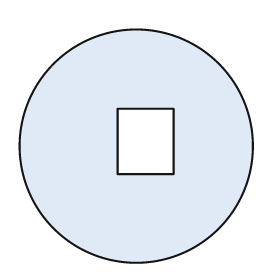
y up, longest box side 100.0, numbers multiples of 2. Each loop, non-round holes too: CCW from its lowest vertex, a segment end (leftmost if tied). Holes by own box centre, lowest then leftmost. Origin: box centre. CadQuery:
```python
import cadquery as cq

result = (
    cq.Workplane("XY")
    .moveTo(0.0, 0.0)
    .circle(50.0)
    .moveTo(-8.0, -12.0)
    .lineTo(16.0, -12.0)
    .lineTo(16.0, 16.0)
    .lineTo(-8.0, 16.0)
    .close()
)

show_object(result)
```